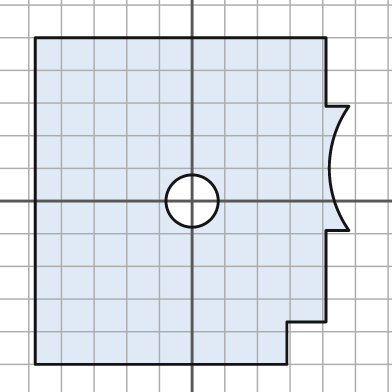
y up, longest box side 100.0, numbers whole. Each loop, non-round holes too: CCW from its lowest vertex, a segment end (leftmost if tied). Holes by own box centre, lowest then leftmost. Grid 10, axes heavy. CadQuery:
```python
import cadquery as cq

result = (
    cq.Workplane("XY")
    .moveTo(-48.0, -50.0)
    .lineTo(29.0, -50.0)
    .lineTo(29.0, -37.0)
    .lineTo(41.0, -37.0)
    .lineTo(41.0, -9.0)
    .lineTo(48.0, -9.0)
    .threePointArc((42.0, 10.0), (48.0, 29.0))
    .lineTo(41.0, 29.0)
    .lineTo(41.0, 50.0)
    .lineTo(-48.0, 50.0)
    .close()
    .moveTo(0.0, 0.0)
    .circle(8.0)
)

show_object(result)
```